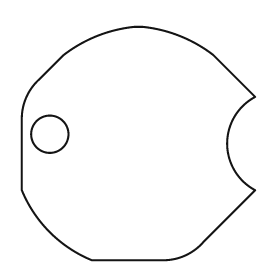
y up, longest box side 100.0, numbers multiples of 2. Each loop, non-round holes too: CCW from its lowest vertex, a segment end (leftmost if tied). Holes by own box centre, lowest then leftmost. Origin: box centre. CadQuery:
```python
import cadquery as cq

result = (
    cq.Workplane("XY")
    .moveTo(-20.0, -50.0)
    .lineTo(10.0, -50.0)
    .threePointArc((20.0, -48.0), (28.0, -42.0))
    .lineTo(50.0, -20.0)
    .threePointArc((38.0, 0.0), (50.0, 20.0))
    .lineTo(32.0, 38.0)
    .threePointArc((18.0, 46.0), (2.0, 50.0))
    .lineTo(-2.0, 50.0)
    .threePointArc((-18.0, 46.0), (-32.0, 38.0))
    .lineTo(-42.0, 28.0)
    .threePointArc((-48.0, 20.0), (-50.0, 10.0))
    .lineTo(-50.0, -20.0)
    .threePointArc((-38.0, -38.0), (-20.0, -50.0))
    .close()
    .moveTo(-38.0, 4.0)
    .circle(8.0)
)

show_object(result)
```